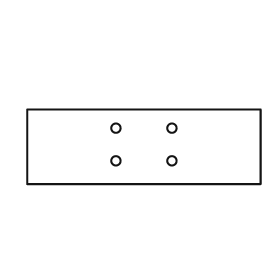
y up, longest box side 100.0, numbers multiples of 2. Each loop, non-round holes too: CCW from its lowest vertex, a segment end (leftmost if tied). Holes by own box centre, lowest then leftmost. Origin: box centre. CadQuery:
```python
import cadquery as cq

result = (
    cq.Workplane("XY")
    .moveTo(-50.0, -16.0)
    .lineTo(50.0, -16.0)
    .lineTo(50.0, 16.0)
    .lineTo(-50.0, 16.0)
    .close()
    .moveTo(-12.0, -6.0)
    .circle(2.0)
    .moveTo(12.0, -6.0)
    .circle(2.0)
    .moveTo(-12.0, 8.0)
    .circle(2.0)
    .moveTo(12.0, 8.0)
    .circle(2.0)
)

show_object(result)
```